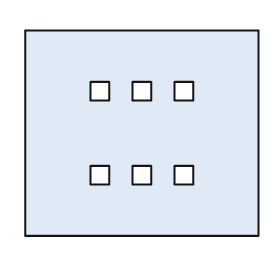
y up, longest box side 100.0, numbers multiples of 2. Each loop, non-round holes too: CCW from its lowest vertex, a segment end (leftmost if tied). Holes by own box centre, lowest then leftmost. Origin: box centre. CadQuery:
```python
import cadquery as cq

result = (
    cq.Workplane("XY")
    .moveTo(-50.0, -44.0)
    .lineTo(50.0, -44.0)
    .lineTo(50.0, 44.0)
    .lineTo(-50.0, 44.0)
    .close()
    .moveTo(-22.0, -22.0)
    .lineTo(-14.0, -22.0)
    .lineTo(-14.0, -14.0)
    .lineTo(-22.0, -14.0)
    .close()
    .moveTo(-4.0, -22.0)
    .lineTo(4.0, -22.0)
    .lineTo(4.0, -14.0)
    .lineTo(-4.0, -14.0)
    .close()
    .moveTo(14.0, -22.0)
    .lineTo(22.0, -22.0)
    .lineTo(22.0, -14.0)
    .lineTo(14.0, -14.0)
    .close()
    .moveTo(-22.0, 14.0)
    .lineTo(-14.0, 14.0)
    .lineTo(-14.0, 22.0)
    .lineTo(-22.0, 22.0)
    .close()
    .moveTo(-4.0, 14.0)
    .lineTo(4.0, 14.0)
    .lineTo(4.0, 22.0)
    .lineTo(-4.0, 22.0)
    .close()
    .moveTo(14.0, 14.0)
    .lineTo(22.0, 14.0)
    .lineTo(22.0, 22.0)
    .lineTo(14.0, 22.0)
    .close()
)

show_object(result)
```